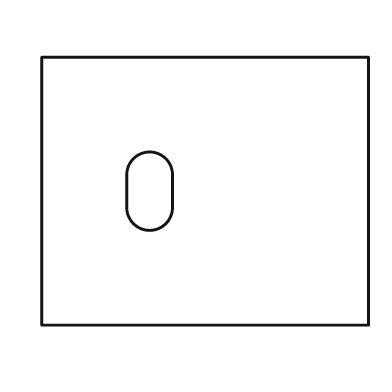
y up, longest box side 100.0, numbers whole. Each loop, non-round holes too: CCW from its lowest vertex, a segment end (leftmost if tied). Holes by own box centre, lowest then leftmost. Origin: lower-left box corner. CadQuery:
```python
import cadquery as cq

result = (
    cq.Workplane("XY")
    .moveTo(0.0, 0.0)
    .lineTo(100.0, 0.0)
    .lineTo(100.0, 82.0)
    .lineTo(0.0, 82.0)
    .close()
    .moveTo(26.0, 36.0)
    .threePointArc((33.0, 29.0), (40.0, 36.0))
    .lineTo(40.0, 46.0)
    .threePointArc((33.0, 53.0), (26.0, 46.0))
    .close()
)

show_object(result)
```